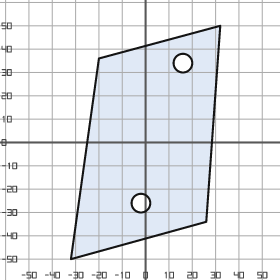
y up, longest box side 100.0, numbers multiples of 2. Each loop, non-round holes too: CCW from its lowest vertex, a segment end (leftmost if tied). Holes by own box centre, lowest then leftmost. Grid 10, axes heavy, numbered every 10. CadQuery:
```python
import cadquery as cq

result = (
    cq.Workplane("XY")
    .moveTo(-32.0, -50.0)
    .lineTo(26.0, -34.0)
    .lineTo(32.0, 50.0)
    .lineTo(-20.0, 36.0)
    .close()
    .moveTo(-2.0, -26.0)
    .circle(4.0)
    .moveTo(16.0, 34.0)
    .circle(4.0)
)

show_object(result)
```